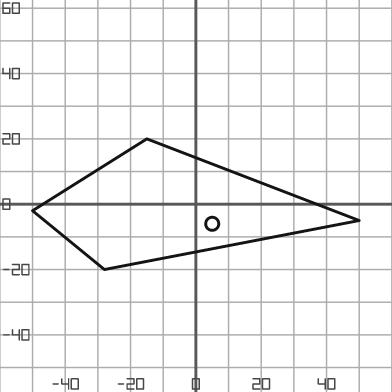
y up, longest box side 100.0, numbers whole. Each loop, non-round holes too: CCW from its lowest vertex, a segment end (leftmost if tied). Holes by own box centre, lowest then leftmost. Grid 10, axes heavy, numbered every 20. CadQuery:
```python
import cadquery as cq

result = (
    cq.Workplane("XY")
    .moveTo(-28.0, -20.0)
    .lineTo(50.0, -5.0)
    .lineTo(-15.0, 20.0)
    .lineTo(-50.0, -2.0)
    .close()
    .moveTo(5.0, -6.0)
    .circle(2.0)
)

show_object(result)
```